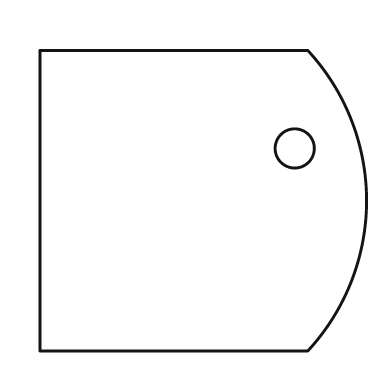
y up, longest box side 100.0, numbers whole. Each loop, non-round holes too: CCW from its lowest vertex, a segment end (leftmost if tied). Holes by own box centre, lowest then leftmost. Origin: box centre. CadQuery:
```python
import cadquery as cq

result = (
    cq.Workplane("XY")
    .moveTo(-50.0, -46.0)
    .lineTo(32.0, -46.0)
    .threePointArc((50.0, 0.0), (32.0, 46.0))
    .lineTo(-50.0, 46.0)
    .close()
    .moveTo(28.0, 16.0)
    .circle(6.0)
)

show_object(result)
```